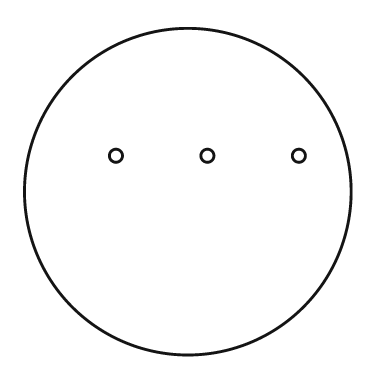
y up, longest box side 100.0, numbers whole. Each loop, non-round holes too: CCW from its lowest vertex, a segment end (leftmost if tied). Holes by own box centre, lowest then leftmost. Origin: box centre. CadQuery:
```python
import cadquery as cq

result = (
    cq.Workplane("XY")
    .moveTo(0.0, 0.0)
    .circle(50.0)
    .moveTo(-22.0, 11.0)
    .circle(2.0)
    .moveTo(6.0, 11.0)
    .circle(2.0)
    .moveTo(34.0, 11.0)
    .circle(2.0)
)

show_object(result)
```